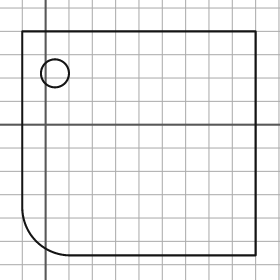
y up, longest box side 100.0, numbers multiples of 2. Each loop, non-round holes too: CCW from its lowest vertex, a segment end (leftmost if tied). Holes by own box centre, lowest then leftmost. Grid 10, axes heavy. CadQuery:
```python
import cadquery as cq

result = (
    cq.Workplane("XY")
    .moveTo(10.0, -56.0)
    .lineTo(90.0, -56.0)
    .lineTo(90.0, 40.0)
    .lineTo(-10.0, 40.0)
    .lineTo(-10.0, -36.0)
    .threePointArc((-4.0, -50.0), (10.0, -56.0))
    .close()
    .moveTo(4.0, 22.0)
    .circle(6.0)
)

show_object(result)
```